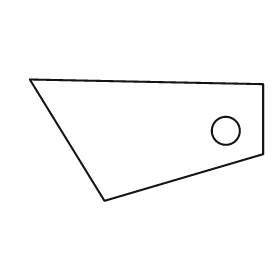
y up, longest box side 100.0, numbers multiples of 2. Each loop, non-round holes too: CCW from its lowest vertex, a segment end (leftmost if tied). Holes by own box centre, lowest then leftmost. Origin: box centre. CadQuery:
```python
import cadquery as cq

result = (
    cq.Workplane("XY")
    .moveTo(-18.0, -26.0)
    .lineTo(50.0, -6.0)
    .lineTo(50.0, 24.0)
    .lineTo(-50.0, 26.0)
    .close()
    .moveTo(34.0, 4.0)
    .circle(6.0)
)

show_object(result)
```